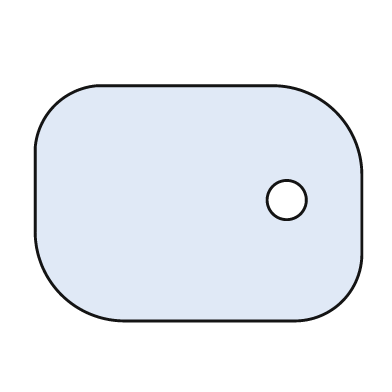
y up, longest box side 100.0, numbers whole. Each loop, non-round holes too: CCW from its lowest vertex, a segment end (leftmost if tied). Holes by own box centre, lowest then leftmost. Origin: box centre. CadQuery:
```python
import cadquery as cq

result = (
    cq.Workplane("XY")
    .moveTo(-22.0, -36.0)
    .lineTo(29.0, -36.0)
    .threePointArc((44.0, -30.0), (50.0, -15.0))
    .lineTo(50.0, 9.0)
    .threePointArc((42.0, 28.0), (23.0, 36.0))
    .lineTo(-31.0, 36.0)
    .threePointArc((-44.0, 30.0), (-50.0, 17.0))
    .lineTo(-50.0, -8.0)
    .threePointArc((-42.0, -28.0), (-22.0, -36.0))
    .close()
    .moveTo(27.0, 1.0)
    .circle(6.0)
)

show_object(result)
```